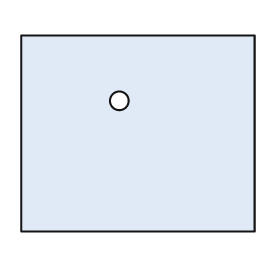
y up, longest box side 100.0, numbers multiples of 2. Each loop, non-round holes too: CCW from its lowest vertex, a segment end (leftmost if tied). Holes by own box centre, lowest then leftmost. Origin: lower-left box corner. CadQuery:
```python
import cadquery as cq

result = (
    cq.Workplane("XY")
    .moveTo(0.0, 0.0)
    .lineTo(100.0, 0.0)
    .lineTo(100.0, 84.0)
    .lineTo(0.0, 84.0)
    .close()
    .moveTo(42.0, 56.0)
    .circle(4.0)
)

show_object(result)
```